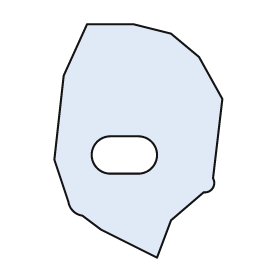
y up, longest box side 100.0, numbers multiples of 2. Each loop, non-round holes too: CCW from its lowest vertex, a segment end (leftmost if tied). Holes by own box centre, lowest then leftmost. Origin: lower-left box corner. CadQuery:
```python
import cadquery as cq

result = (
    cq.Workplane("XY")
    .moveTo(44.0, 0.0)
    .lineTo(50.0, 16.0)
    .lineTo(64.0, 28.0)
    .threePointArc((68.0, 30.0), (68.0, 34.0))
    .lineTo(72.0, 68.0)
    .lineTo(62.0, 86.0)
    .lineTo(50.0, 96.0)
    .lineTo(34.0, 100.0)
    .lineTo(14.0, 100.0)
    .lineTo(4.0, 78.0)
    .lineTo(0.0, 42.0)
    .lineTo(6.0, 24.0)
    .threePointArc((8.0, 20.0), (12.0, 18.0))
    .lineTo(20.0, 12.0)
    .close()
    .moveTo(24.0, 36.0)
    .lineTo(36.0, 36.0)
    .threePointArc((44.0, 44.0), (36.0, 52.0))
    .lineTo(24.0, 52.0)
    .threePointArc((16.0, 44.0), (24.0, 36.0))
    .close()
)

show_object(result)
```